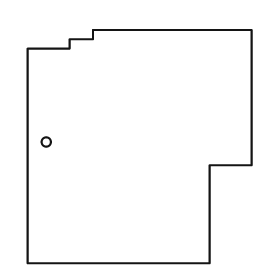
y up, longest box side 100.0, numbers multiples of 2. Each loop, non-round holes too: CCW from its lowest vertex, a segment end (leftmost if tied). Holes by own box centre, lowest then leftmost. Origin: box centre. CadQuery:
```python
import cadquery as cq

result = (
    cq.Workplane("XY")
    .moveTo(-48.0, -50.0)
    .lineTo(30.0, -50.0)
    .lineTo(30.0, -8.0)
    .lineTo(48.0, -8.0)
    .lineTo(48.0, 50.0)
    .lineTo(-20.0, 50.0)
    .lineTo(-20.0, 46.0)
    .lineTo(-30.0, 46.0)
    .lineTo(-30.0, 42.0)
    .lineTo(-48.0, 42.0)
    .close()
    .moveTo(-40.0, 2.0)
    .circle(2.0)
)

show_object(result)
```